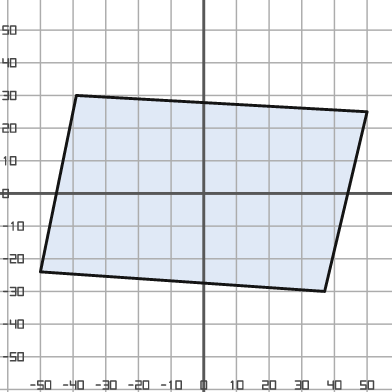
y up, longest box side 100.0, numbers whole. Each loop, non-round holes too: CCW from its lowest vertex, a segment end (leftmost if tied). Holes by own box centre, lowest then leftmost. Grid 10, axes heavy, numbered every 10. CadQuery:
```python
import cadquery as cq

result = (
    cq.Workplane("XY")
    .moveTo(37.0, -30.0)
    .lineTo(50.0, 25.0)
    .lineTo(-39.0, 30.0)
    .lineTo(-50.0, -24.0)
    .close()
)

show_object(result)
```